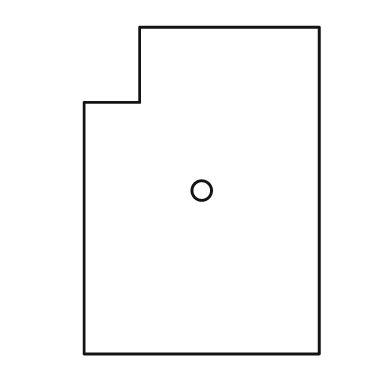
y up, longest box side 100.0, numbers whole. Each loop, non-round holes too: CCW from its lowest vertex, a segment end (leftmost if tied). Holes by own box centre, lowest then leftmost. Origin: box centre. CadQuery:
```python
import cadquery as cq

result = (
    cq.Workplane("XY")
    .moveTo(-36.0, -50.0)
    .lineTo(36.0, -50.0)
    .lineTo(36.0, 50.0)
    .lineTo(-19.0, 50.0)
    .lineTo(-19.0, 27.0)
    .lineTo(-36.0, 27.0)
    .close()
    .moveTo(0.0, 0.0)
    .circle(3.0)
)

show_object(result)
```